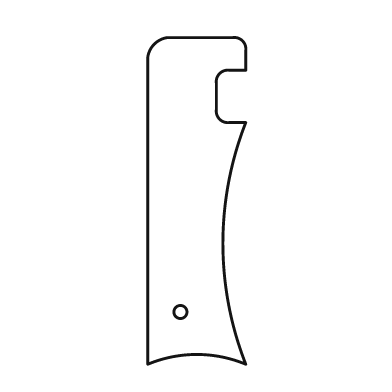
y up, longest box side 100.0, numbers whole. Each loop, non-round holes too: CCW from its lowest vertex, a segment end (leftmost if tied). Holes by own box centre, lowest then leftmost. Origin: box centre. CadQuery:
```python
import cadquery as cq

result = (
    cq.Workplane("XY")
    .moveTo(-15.0, -50.0)
    .threePointArc((0.0, -47.0), (15.0, -50.0))
    .threePointArc((8.0, -13.0), (15.0, 24.0))
    .lineTo(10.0, 24.0)
    .threePointArc((7.0, 25.0), (6.0, 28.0))
    .lineTo(6.0, 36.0)
    .threePointArc((7.0, 39.0), (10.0, 40.0))
    .lineTo(15.0, 40.0)
    .lineTo(15.0, 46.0)
    .threePointArc((14.0, 49.0), (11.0, 50.0))
    .lineTo(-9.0, 50.0)
    .threePointArc((-13.0, 48.0), (-15.0, 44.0))
    .close()
    .moveTo(-5.0, -34.0)
    .circle(2.0)
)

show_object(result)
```